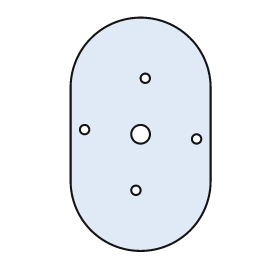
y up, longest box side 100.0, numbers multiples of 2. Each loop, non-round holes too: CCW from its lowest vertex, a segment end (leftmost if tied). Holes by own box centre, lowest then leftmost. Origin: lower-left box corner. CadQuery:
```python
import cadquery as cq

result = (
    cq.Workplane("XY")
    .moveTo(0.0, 30.0)
    .threePointArc((30.0, 0.0), (60.0, 30.0))
    .lineTo(60.0, 70.0)
    .threePointArc((30.0, 100.0), (0.0, 70.0))
    .close()
    .moveTo(28.0, 26.0)
    .circle(2.0)
    .moveTo(54.0, 48.0)
    .circle(2.0)
    .moveTo(30.0, 50.0)
    .circle(4.0)
    .moveTo(6.0, 52.0)
    .circle(2.0)
    .moveTo(32.0, 74.0)
    .circle(2.0)
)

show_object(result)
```